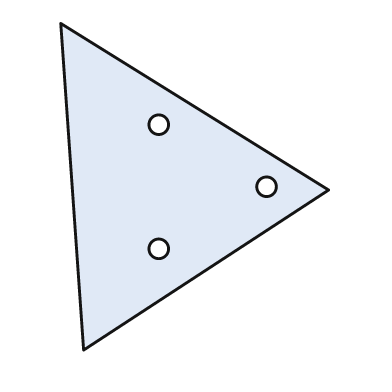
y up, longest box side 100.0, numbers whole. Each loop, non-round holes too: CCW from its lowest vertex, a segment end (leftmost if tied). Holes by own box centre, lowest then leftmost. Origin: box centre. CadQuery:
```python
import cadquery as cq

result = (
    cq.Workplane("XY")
    .moveTo(-34.0, -50.0)
    .lineTo(41.0, -1.0)
    .lineTo(-41.0, 50.0)
    .close()
    .moveTo(-11.0, -19.0)
    .circle(3.0)
    .moveTo(22.0, 0.0)
    .circle(3.0)
    .moveTo(-11.0, 19.0)
    .circle(3.0)
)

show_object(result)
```